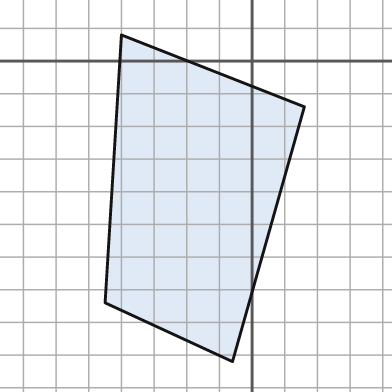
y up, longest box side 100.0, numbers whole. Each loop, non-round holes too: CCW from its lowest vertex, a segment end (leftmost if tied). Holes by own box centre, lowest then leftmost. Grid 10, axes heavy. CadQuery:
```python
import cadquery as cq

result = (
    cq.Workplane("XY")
    .moveTo(-6.0, -92.0)
    .lineTo(16.0, -14.0)
    .lineTo(-40.0, 8.0)
    .lineTo(-45.0, -74.0)
    .close()
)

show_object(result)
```